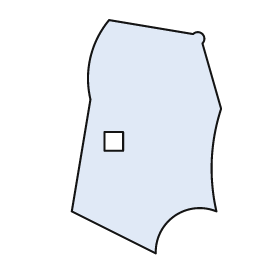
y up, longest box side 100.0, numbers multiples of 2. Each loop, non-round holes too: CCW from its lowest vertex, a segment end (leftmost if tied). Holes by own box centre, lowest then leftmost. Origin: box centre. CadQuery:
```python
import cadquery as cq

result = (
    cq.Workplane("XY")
    .moveTo(4.0, -50.0)
    .threePointArc((12.0, -34.0), (30.0, -32.0))
    .threePointArc((28.0, -10.0), (32.0, 12.0))
    .lineTo(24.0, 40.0)
    .threePointArc((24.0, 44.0), (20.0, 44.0))
    .lineTo(-16.0, 50.0)
    .threePointArc((-24.0, 34.0), (-24.0, 16.0))
    .lineTo(-32.0, -32.0)
    .close()
    .moveTo(-18.0, -6.0)
    .lineTo(-10.0, -6.0)
    .lineTo(-10.0, 2.0)
    .lineTo(-18.0, 2.0)
    .close()
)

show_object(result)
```